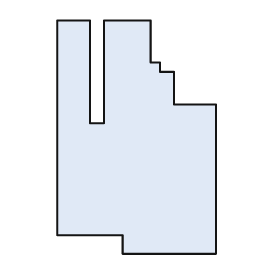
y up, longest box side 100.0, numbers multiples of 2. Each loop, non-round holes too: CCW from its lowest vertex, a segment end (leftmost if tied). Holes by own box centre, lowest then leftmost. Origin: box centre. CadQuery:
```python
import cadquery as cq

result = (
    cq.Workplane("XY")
    .moveTo(-6.0, -50.0)
    .lineTo(34.0, -50.0)
    .lineTo(34.0, 14.0)
    .lineTo(16.0, 14.0)
    .lineTo(16.0, 28.0)
    .lineTo(10.0, 28.0)
    .lineTo(10.0, 32.0)
    .lineTo(6.0, 32.0)
    .lineTo(6.0, 50.0)
    .lineTo(-14.0, 50.0)
    .lineTo(-14.0, 6.0)
    .lineTo(-20.0, 6.0)
    .lineTo(-20.0, 50.0)
    .lineTo(-34.0, 50.0)
    .lineTo(-34.0, -42.0)
    .lineTo(-6.0, -42.0)
    .close()
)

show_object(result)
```